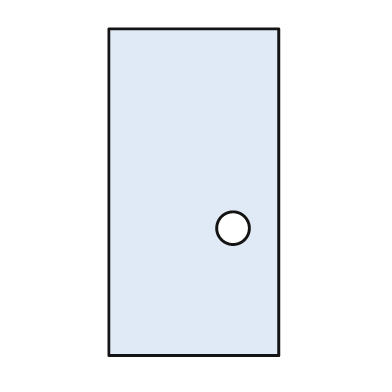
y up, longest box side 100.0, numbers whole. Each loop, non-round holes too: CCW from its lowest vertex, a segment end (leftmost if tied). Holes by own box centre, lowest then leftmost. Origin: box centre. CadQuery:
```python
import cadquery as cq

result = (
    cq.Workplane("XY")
    .moveTo(-26.0, -50.0)
    .lineTo(26.0, -50.0)
    .lineTo(26.0, 50.0)
    .lineTo(-26.0, 50.0)
    .close()
    .moveTo(12.0, -11.0)
    .circle(5.0)
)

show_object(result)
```